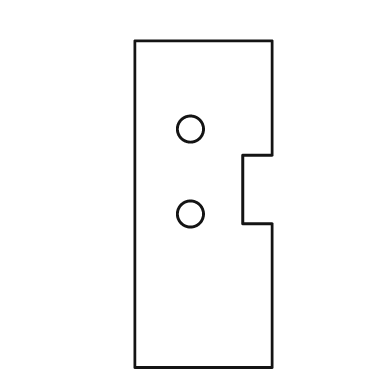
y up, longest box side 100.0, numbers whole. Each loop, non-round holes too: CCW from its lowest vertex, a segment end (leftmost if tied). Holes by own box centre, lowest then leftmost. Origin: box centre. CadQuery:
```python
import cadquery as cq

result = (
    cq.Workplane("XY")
    .moveTo(-21.0, -50.0)
    .lineTo(21.0, -50.0)
    .lineTo(21.0, -6.0)
    .lineTo(12.0, -6.0)
    .lineTo(12.0, 15.0)
    .lineTo(21.0, 15.0)
    .lineTo(21.0, 50.0)
    .lineTo(-21.0, 50.0)
    .close()
    .moveTo(-4.0, -3.0)
    .circle(4.0)
    .moveTo(-4.0, 23.0)
    .circle(4.0)
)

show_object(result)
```